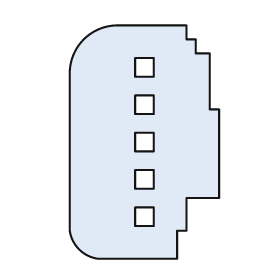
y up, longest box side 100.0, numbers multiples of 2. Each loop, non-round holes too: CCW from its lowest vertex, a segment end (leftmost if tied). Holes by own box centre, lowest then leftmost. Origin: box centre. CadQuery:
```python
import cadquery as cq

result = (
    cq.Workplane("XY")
    .moveTo(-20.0, -50.0)
    .lineTo(14.0, -50.0)
    .lineTo(14.0, -38.0)
    .lineTo(18.0, -38.0)
    .lineTo(18.0, -24.0)
    .lineTo(32.0, -24.0)
    .lineTo(32.0, 14.0)
    .lineTo(28.0, 14.0)
    .lineTo(28.0, 38.0)
    .lineTo(22.0, 38.0)
    .lineTo(22.0, 44.0)
    .lineTo(18.0, 44.0)
    .lineTo(18.0, 50.0)
    .lineTo(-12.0, 50.0)
    .threePointArc((-26.0, 44.0), (-32.0, 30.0))
    .lineTo(-32.0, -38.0)
    .threePointArc((-28.0, -46.0), (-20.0, -50.0))
    .close()
    .moveTo(-4.0, -36.0)
    .lineTo(4.0, -36.0)
    .lineTo(4.0, -28.0)
    .lineTo(-4.0, -28.0)
    .close()
    .moveTo(-4.0, -20.0)
    .lineTo(4.0, -20.0)
    .lineTo(4.0, -12.0)
    .lineTo(-4.0, -12.0)
    .close()
    .moveTo(-4.0, -4.0)
    .lineTo(4.0, -4.0)
    .lineTo(4.0, 4.0)
    .lineTo(-4.0, 4.0)
    .close()
    .moveTo(-4.0, 12.0)
    .lineTo(4.0, 12.0)
    .lineTo(4.0, 20.0)
    .lineTo(-4.0, 20.0)
    .close()
    .moveTo(-4.0, 28.0)
    .lineTo(4.0, 28.0)
    .lineTo(4.0, 36.0)
    .lineTo(-4.0, 36.0)
    .close()
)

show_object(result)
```